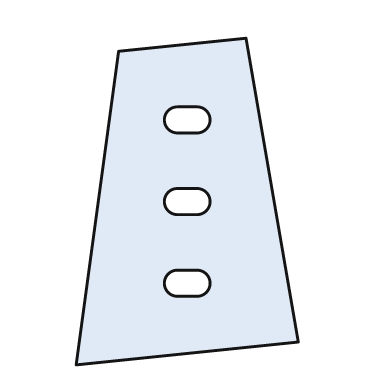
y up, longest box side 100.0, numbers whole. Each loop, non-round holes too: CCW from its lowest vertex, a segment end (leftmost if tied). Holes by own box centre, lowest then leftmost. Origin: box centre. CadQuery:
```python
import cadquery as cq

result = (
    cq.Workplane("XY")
    .moveTo(-34.0, -50.0)
    .lineTo(34.0, -43.0)
    .lineTo(18.0, 50.0)
    .lineTo(-21.0, 46.0)
    .close()
    .moveTo(-3.0, -29.0)
    .lineTo(3.0, -29.0)
    .threePointArc((7.0, -25.0), (3.0, -21.0))
    .lineTo(-3.0, -21.0)
    .threePointArc((-7.0, -25.0), (-3.0, -29.0))
    .close()
    .moveTo(-3.0, -4.0)
    .lineTo(3.0, -4.0)
    .threePointArc((7.0, 0.0), (3.0, 4.0))
    .lineTo(-3.0, 4.0)
    .threePointArc((-7.0, 0.0), (-3.0, -4.0))
    .close()
    .moveTo(-3.0, 21.0)
    .lineTo(3.0, 21.0)
    .threePointArc((7.0, 25.0), (3.0, 29.0))
    .lineTo(-3.0, 29.0)
    .threePointArc((-7.0, 25.0), (-3.0, 21.0))
    .close()
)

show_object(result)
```